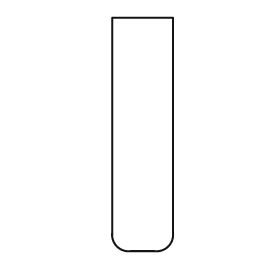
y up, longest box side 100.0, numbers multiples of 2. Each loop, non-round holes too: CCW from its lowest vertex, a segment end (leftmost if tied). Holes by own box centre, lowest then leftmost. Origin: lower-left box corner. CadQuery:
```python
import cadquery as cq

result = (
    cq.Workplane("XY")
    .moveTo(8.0, 0.0)
    .lineTo(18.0, 0.0)
    .threePointArc((24.0, 2.0), (26.0, 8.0))
    .lineTo(26.0, 100.0)
    .lineTo(0.0, 100.0)
    .lineTo(0.0, 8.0)
    .threePointArc((2.0, 2.0), (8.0, 0.0))
    .close()
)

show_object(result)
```